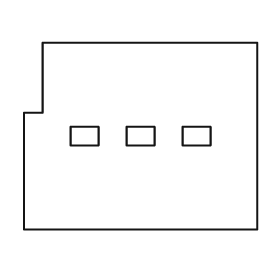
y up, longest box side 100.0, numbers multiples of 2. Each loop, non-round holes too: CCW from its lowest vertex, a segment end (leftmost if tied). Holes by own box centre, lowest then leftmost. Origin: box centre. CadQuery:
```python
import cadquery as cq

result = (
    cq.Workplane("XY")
    .moveTo(-50.0, -40.0)
    .lineTo(50.0, -40.0)
    .lineTo(50.0, 40.0)
    .lineTo(-42.0, 40.0)
    .lineTo(-42.0, 10.0)
    .lineTo(-50.0, 10.0)
    .close()
    .moveTo(-30.0, -4.0)
    .lineTo(-18.0, -4.0)
    .lineTo(-18.0, 4.0)
    .lineTo(-30.0, 4.0)
    .close()
    .moveTo(-6.0, -4.0)
    .lineTo(6.0, -4.0)
    .lineTo(6.0, 4.0)
    .lineTo(-6.0, 4.0)
    .close()
    .moveTo(18.0, -4.0)
    .lineTo(30.0, -4.0)
    .lineTo(30.0, 4.0)
    .lineTo(18.0, 4.0)
    .close()
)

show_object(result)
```